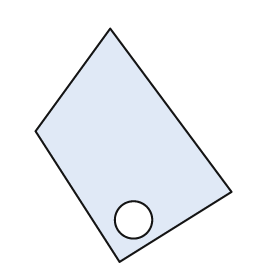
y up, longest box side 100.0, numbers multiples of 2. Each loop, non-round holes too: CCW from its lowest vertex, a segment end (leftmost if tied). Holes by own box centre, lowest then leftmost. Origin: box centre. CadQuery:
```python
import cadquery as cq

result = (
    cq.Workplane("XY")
    .moveTo(-6.0, -50.0)
    .lineTo(42.0, -20.0)
    .lineTo(-10.0, 50.0)
    .lineTo(-42.0, 6.0)
    .close()
    .moveTo(0.0, -32.0)
    .circle(8.0)
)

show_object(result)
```